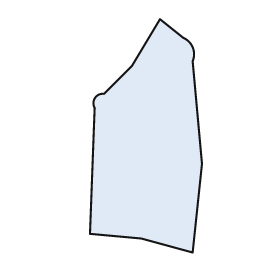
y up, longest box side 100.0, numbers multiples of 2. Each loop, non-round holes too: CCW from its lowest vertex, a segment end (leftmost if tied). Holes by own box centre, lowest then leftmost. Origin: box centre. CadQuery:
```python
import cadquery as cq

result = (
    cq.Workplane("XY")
    .moveTo(20.0, -50.0)
    .lineTo(24.0, -12.0)
    .lineTo(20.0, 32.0)
    .threePointArc((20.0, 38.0), (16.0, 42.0))
    .lineTo(6.0, 50.0)
    .lineTo(-6.0, 30.0)
    .lineTo(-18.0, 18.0)
    .threePointArc((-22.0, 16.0), (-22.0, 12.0))
    .lineTo(-24.0, -42.0)
    .lineTo(-2.0, -44.0)
    .close()
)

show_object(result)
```